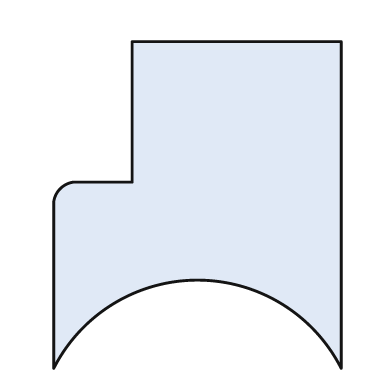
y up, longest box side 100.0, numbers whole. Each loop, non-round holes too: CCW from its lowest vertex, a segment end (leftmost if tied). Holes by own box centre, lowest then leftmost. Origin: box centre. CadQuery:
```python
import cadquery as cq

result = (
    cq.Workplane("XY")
    .moveTo(-44.0, -50.0)
    .threePointArc((0.0, -23.0), (44.0, -50.0))
    .lineTo(44.0, 50.0)
    .lineTo(-20.0, 50.0)
    .lineTo(-20.0, 7.0)
    .lineTo(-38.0, 7.0)
    .threePointArc((-42.0, 5.0), (-44.0, 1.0))
    .close()
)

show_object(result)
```